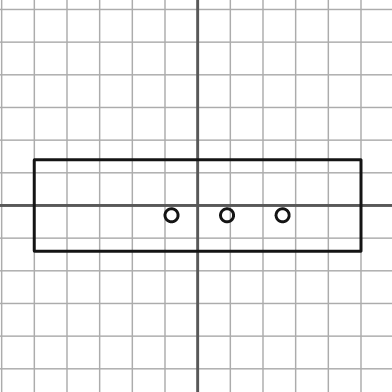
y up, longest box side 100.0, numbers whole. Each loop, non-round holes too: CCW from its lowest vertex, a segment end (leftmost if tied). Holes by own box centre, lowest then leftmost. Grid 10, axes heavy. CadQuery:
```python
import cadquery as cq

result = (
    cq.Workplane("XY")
    .moveTo(-50.0, -14.0)
    .lineTo(50.0, -14.0)
    .lineTo(50.0, 14.0)
    .lineTo(-50.0, 14.0)
    .close()
    .moveTo(-8.0, -3.0)
    .circle(2.0)
    .moveTo(9.0, -3.0)
    .circle(2.0)
    .moveTo(26.0, -3.0)
    .circle(2.0)
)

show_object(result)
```